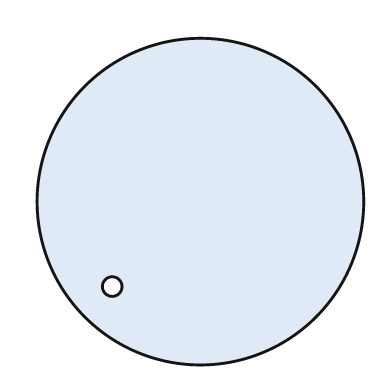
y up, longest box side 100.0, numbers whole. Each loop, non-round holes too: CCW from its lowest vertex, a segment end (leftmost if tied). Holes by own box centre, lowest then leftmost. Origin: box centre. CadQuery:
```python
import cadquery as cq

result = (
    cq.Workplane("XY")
    .moveTo(0.0, 0.0)
    .circle(50.0)
    .moveTo(-27.0, -26.0)
    .circle(3.0)
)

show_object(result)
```